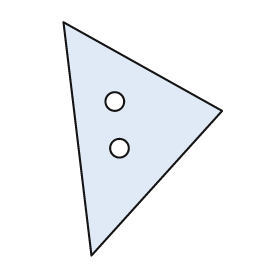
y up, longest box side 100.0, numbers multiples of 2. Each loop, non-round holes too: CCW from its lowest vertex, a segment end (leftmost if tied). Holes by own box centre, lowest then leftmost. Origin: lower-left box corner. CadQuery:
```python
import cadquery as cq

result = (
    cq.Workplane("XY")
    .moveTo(12.0, 0.0)
    .lineTo(68.0, 62.0)
    .lineTo(0.0, 100.0)
    .close()
    .moveTo(24.0, 46.0)
    .circle(4.0)
    .moveTo(22.0, 66.0)
    .circle(4.0)
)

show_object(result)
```